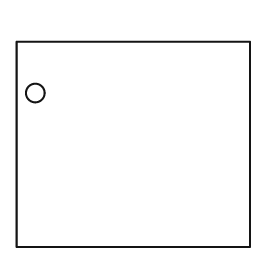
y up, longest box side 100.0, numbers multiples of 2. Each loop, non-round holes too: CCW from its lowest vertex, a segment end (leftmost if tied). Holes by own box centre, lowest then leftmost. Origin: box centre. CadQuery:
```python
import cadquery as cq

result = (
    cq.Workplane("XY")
    .moveTo(-50.0, -44.0)
    .lineTo(50.0, -44.0)
    .lineTo(50.0, 44.0)
    .lineTo(-50.0, 44.0)
    .close()
    .moveTo(-42.0, 22.0)
    .circle(4.0)
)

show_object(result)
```